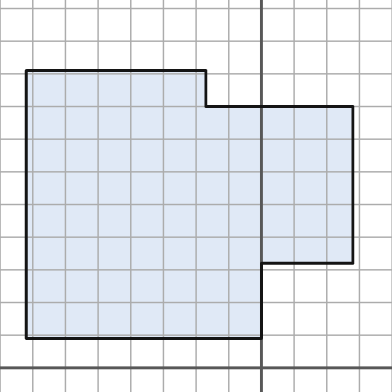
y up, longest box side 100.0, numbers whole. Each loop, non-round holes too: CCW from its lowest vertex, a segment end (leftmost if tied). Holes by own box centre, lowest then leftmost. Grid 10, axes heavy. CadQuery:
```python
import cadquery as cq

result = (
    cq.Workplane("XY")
    .moveTo(-72.0, 9.0)
    .lineTo(0.0, 9.0)
    .lineTo(0.0, 32.0)
    .lineTo(28.0, 32.0)
    .lineTo(28.0, 80.0)
    .lineTo(-17.0, 80.0)
    .lineTo(-17.0, 91.0)
    .lineTo(-72.0, 91.0)
    .close()
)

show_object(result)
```